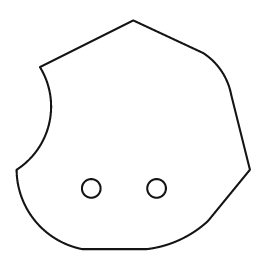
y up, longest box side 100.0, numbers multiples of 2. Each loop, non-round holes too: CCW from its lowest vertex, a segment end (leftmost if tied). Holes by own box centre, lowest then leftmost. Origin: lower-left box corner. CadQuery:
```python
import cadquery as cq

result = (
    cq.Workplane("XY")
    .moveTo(28.0, 0.0)
    .lineTo(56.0, 0.0)
    .threePointArc((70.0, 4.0), (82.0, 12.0))
    .lineTo(100.0, 34.0)
    .lineTo(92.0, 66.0)
    .threePointArc((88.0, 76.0), (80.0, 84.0))
    .lineTo(50.0, 98.0)
    .lineTo(10.0, 78.0)
    .threePointArc((14.0, 54.0), (0.0, 34.0))
    .threePointArc((8.0, 12.0), (28.0, 0.0))
    .close()
    .moveTo(32.0, 26.0)
    .circle(4.0)
    .moveTo(60.0, 26.0)
    .circle(4.0)
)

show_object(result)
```